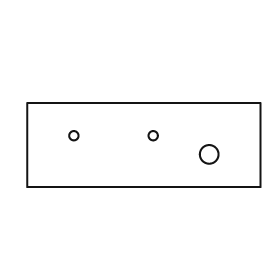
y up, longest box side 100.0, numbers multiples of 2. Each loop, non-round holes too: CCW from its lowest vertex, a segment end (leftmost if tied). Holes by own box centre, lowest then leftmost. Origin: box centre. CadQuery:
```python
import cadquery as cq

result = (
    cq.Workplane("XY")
    .moveTo(-50.0, -18.0)
    .lineTo(50.0, -18.0)
    .lineTo(50.0, 18.0)
    .lineTo(-50.0, 18.0)
    .close()
    .moveTo(28.0, -4.0)
    .circle(4.0)
    .moveTo(-30.0, 4.0)
    .circle(2.0)
    .moveTo(4.0, 4.0)
    .circle(2.0)
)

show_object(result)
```